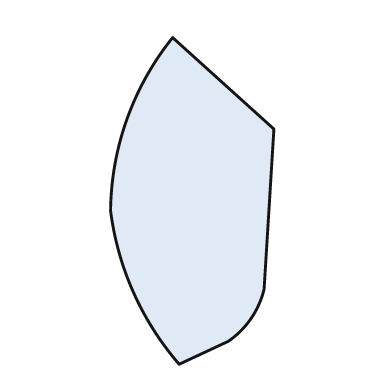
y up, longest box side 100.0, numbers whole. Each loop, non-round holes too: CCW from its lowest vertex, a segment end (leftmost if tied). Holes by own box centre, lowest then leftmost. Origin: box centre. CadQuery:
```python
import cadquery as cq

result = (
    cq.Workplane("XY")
    .moveTo(-4.0, -50.0)
    .lineTo(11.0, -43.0)
    .threePointArc((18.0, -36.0), (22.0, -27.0))
    .lineTo(25.0, 22.0)
    .lineTo(-6.0, 50.0)
    .threePointArc((-20.0, 25.0), (-25.0, -3.0))
    .threePointArc((-18.0, -28.0), (-4.0, -50.0))
    .close()
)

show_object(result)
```